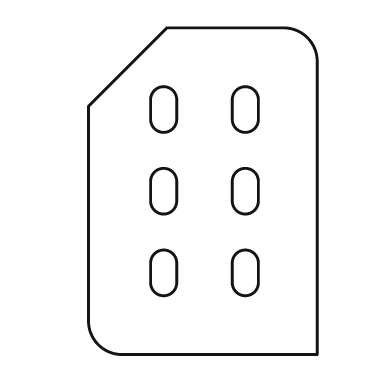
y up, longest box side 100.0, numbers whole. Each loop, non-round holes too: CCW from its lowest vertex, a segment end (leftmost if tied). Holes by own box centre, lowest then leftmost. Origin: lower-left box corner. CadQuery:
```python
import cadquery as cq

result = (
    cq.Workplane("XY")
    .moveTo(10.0, 0.0)
    .lineTo(70.0, 0.0)
    .lineTo(70.0, 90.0)
    .threePointArc((67.0, 97.0), (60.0, 100.0))
    .lineTo(24.0, 100.0)
    .lineTo(0.0, 76.0)
    .lineTo(0.0, 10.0)
    .threePointArc((3.0, 3.0), (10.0, 0.0))
    .close()
    .moveTo(19.0, 22.0)
    .threePointArc((23.0, 18.0), (27.0, 22.0))
    .lineTo(27.0, 28.0)
    .threePointArc((23.0, 32.0), (19.0, 28.0))
    .close()
    .moveTo(44.0, 22.0)
    .threePointArc((48.0, 18.0), (52.0, 22.0))
    .lineTo(52.0, 28.0)
    .threePointArc((48.0, 32.0), (44.0, 28.0))
    .close()
    .moveTo(19.0, 47.0)
    .threePointArc((23.0, 43.0), (27.0, 47.0))
    .lineTo(27.0, 53.0)
    .threePointArc((23.0, 57.0), (19.0, 53.0))
    .close()
    .moveTo(44.0, 47.0)
    .threePointArc((48.0, 43.0), (52.0, 47.0))
    .lineTo(52.0, 53.0)
    .threePointArc((48.0, 57.0), (44.0, 53.0))
    .close()
    .moveTo(19.0, 72.0)
    .threePointArc((23.0, 68.0), (27.0, 72.0))
    .lineTo(27.0, 78.0)
    .threePointArc((23.0, 82.0), (19.0, 78.0))
    .close()
    .moveTo(44.0, 72.0)
    .threePointArc((48.0, 68.0), (52.0, 72.0))
    .lineTo(52.0, 78.0)
    .threePointArc((48.0, 82.0), (44.0, 78.0))
    .close()
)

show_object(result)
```